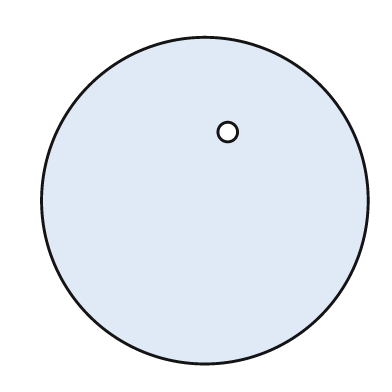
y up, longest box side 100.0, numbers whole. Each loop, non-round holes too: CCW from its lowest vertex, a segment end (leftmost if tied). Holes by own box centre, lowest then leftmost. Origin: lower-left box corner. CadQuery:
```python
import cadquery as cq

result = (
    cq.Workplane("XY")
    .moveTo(50.0, 50.0)
    .circle(50.0)
    .moveTo(57.0, 71.0)
    .circle(3.0)
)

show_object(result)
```